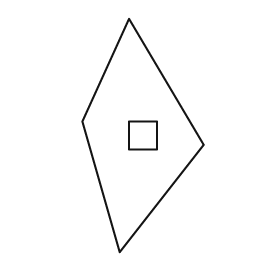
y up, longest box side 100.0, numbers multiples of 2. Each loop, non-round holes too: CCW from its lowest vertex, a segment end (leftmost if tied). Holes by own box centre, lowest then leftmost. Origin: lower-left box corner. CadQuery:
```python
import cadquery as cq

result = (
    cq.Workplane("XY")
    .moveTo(16.0, 0.0)
    .lineTo(52.0, 46.0)
    .lineTo(20.0, 100.0)
    .lineTo(0.0, 56.0)
    .close()
    .moveTo(20.0, 44.0)
    .lineTo(32.0, 44.0)
    .lineTo(32.0, 56.0)
    .lineTo(20.0, 56.0)
    .close()
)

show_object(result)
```